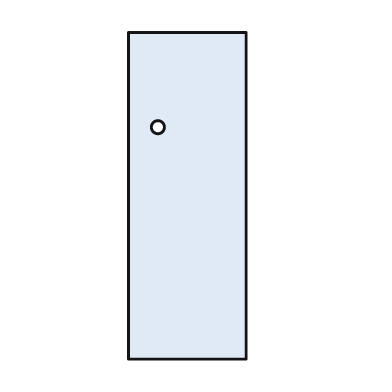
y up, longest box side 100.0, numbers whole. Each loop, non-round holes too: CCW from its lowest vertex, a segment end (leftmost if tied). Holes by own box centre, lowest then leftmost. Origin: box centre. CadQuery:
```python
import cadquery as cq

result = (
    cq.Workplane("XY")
    .moveTo(-18.0, -50.0)
    .lineTo(18.0, -50.0)
    .lineTo(18.0, 50.0)
    .lineTo(-18.0, 50.0)
    .close()
    .moveTo(-9.0, 21.0)
    .circle(2.0)
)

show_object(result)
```